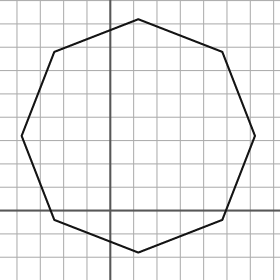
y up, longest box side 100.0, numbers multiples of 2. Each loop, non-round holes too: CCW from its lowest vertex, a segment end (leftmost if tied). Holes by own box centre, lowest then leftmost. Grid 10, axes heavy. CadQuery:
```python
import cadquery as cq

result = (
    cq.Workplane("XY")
    .moveTo(12.0, -18.0)
    .lineTo(48.0, -4.0)
    .lineTo(62.0, 32.0)
    .lineTo(48.0, 68.0)
    .lineTo(12.0, 82.0)
    .lineTo(-24.0, 68.0)
    .lineTo(-38.0, 32.0)
    .lineTo(-24.0, -4.0)
    .close()
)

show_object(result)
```